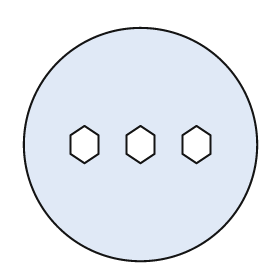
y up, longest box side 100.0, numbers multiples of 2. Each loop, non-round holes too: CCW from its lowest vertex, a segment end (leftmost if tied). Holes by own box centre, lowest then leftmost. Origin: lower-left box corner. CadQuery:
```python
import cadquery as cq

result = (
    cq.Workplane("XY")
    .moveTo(50.0, 50.0)
    .circle(50.0)
    .moveTo(26.0, 42.0)
    .lineTo(32.0, 46.0)
    .lineTo(32.0, 54.0)
    .lineTo(26.0, 58.0)
    .lineTo(20.0, 54.0)
    .lineTo(20.0, 46.0)
    .close()
    .moveTo(50.0, 42.0)
    .lineTo(56.0, 46.0)
    .lineTo(56.0, 54.0)
    .lineTo(50.0, 58.0)
    .lineTo(44.0, 54.0)
    .lineTo(44.0, 46.0)
    .close()
    .moveTo(74.0, 42.0)
    .lineTo(80.0, 46.0)
    .lineTo(80.0, 54.0)
    .lineTo(74.0, 58.0)
    .lineTo(68.0, 54.0)
    .lineTo(68.0, 46.0)
    .close()
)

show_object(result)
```